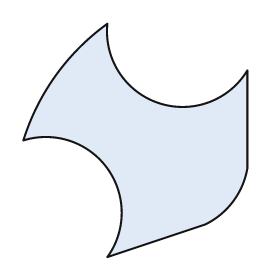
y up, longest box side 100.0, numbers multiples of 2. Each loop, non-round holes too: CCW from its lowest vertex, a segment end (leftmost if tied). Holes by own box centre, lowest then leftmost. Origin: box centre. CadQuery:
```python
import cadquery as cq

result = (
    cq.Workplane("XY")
    .moveTo(-12.0, -50.0)
    .lineTo(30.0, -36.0)
    .threePointArc((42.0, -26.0), (48.0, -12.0))
    .lineTo(48.0, 30.0)
    .threePointArc((10.0, 16.0), (-12.0, 50.0))
    .threePointArc((-34.0, 28.0), (-48.0, 0.0))
    .threePointArc((-12.0, -12.0), (-12.0, -50.0))
    .close()
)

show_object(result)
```